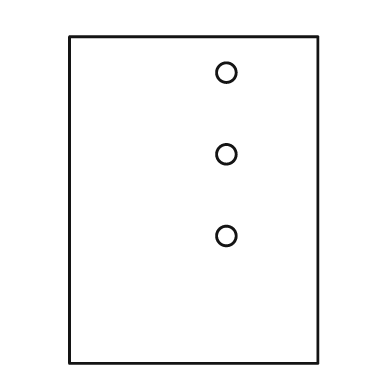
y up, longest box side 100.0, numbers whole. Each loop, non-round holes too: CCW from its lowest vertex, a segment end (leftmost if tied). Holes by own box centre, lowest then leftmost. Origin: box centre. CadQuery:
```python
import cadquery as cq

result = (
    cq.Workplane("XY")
    .moveTo(-38.0, -50.0)
    .lineTo(38.0, -50.0)
    .lineTo(38.0, 50.0)
    .lineTo(-38.0, 50.0)
    .close()
    .moveTo(10.0, -11.0)
    .circle(3.0)
    .moveTo(10.0, 14.0)
    .circle(3.0)
    .moveTo(10.0, 39.0)
    .circle(3.0)
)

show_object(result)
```